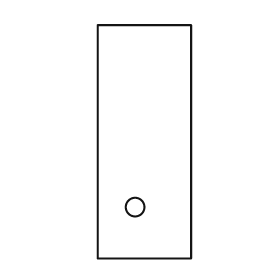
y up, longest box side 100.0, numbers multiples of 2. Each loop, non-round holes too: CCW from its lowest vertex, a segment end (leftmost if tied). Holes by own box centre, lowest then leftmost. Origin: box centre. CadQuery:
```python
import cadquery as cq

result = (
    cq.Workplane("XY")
    .moveTo(-20.0, -50.0)
    .lineTo(20.0, -50.0)
    .lineTo(20.0, 50.0)
    .lineTo(-20.0, 50.0)
    .close()
    .moveTo(-4.0, -28.0)
    .circle(4.0)
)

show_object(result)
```